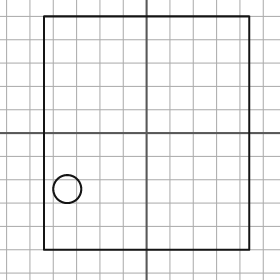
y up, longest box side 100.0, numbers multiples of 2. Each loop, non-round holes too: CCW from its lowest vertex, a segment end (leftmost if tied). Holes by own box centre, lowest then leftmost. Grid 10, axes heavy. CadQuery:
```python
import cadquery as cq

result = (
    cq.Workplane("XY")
    .moveTo(-44.0, -50.0)
    .lineTo(44.0, -50.0)
    .lineTo(44.0, 50.0)
    .lineTo(-44.0, 50.0)
    .close()
    .moveTo(-34.0, -24.0)
    .circle(6.0)
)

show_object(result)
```